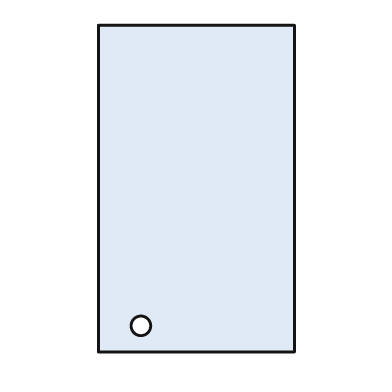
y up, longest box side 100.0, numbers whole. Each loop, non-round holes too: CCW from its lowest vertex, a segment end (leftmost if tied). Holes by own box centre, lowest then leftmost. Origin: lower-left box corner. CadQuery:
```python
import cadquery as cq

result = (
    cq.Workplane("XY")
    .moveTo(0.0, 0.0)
    .lineTo(60.0, 0.0)
    .lineTo(60.0, 100.0)
    .lineTo(0.0, 100.0)
    .close()
    .moveTo(13.0, 8.0)
    .circle(3.0)
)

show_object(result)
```